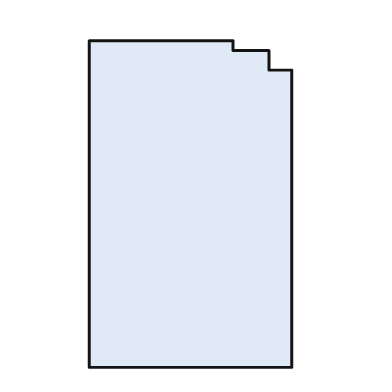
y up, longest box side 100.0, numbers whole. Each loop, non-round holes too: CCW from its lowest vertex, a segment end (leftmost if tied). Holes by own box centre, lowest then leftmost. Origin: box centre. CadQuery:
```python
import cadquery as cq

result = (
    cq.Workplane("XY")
    .moveTo(-31.0, -50.0)
    .lineTo(31.0, -50.0)
    .lineTo(31.0, 41.0)
    .lineTo(24.0, 41.0)
    .lineTo(24.0, 47.0)
    .lineTo(13.0, 47.0)
    .lineTo(13.0, 50.0)
    .lineTo(-31.0, 50.0)
    .close()
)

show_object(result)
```